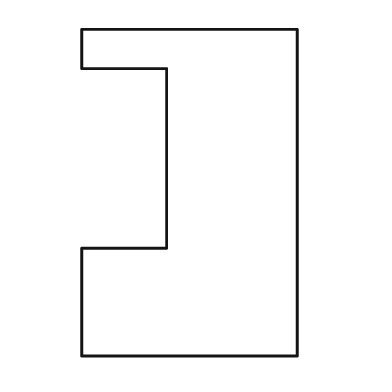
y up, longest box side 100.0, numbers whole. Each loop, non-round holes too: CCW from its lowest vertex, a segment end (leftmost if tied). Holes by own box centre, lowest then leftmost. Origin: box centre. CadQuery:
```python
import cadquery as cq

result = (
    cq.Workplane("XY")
    .moveTo(-33.0, -50.0)
    .lineTo(33.0, -50.0)
    .lineTo(33.0, 50.0)
    .lineTo(-33.0, 50.0)
    .lineTo(-33.0, 38.0)
    .lineTo(-7.0, 38.0)
    .lineTo(-7.0, -17.0)
    .lineTo(-33.0, -17.0)
    .close()
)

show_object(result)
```